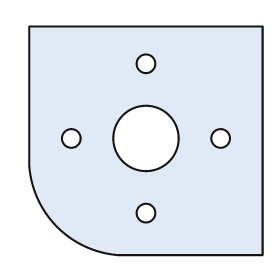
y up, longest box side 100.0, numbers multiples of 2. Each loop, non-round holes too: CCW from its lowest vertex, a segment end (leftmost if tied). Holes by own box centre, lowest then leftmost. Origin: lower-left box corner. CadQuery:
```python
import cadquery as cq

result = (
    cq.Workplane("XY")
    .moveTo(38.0, 0.0)
    .lineTo(100.0, 0.0)
    .lineTo(100.0, 98.0)
    .lineTo(0.0, 98.0)
    .lineTo(0.0, 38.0)
    .threePointArc((12.0, 12.0), (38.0, 0.0))
    .close()
    .moveTo(50.0, 18.0)
    .circle(4.0)
    .moveTo(18.0, 50.0)
    .circle(4.0)
    .moveTo(50.0, 50.0)
    .circle(14.0)
    .moveTo(82.0, 50.0)
    .circle(4.0)
    .moveTo(50.0, 82.0)
    .circle(4.0)
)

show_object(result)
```